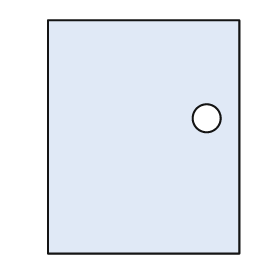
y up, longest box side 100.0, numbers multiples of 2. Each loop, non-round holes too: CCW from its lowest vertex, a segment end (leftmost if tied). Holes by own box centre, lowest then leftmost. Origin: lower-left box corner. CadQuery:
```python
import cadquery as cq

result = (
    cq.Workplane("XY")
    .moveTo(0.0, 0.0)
    .lineTo(82.0, 0.0)
    .lineTo(82.0, 100.0)
    .lineTo(0.0, 100.0)
    .close()
    .moveTo(68.0, 58.0)
    .circle(6.0)
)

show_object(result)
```